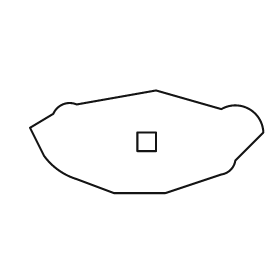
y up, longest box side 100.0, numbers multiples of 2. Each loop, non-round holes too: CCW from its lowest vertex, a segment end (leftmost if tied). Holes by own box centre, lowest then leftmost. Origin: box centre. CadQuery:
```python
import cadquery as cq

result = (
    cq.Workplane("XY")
    .moveTo(-14.0, -22.0)
    .lineTo(8.0, -22.0)
    .lineTo(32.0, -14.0)
    .threePointArc((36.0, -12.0), (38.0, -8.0))
    .lineTo(50.0, 4.0)
    .threePointArc((44.0, 14.0), (32.0, 14.0))
    .lineTo(4.0, 22.0)
    .lineTo(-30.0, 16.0)
    .threePointArc((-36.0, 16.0), (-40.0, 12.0))
    .lineTo(-50.0, 6.0)
    .lineTo(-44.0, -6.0)
    .threePointArc((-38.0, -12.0), (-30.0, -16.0))
    .close()
    .moveTo(-4.0, -4.0)
    .lineTo(4.0, -4.0)
    .lineTo(4.0, 4.0)
    .lineTo(-4.0, 4.0)
    .close()
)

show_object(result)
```